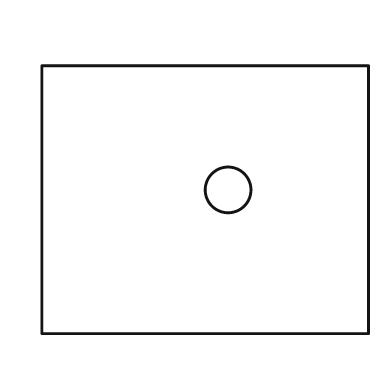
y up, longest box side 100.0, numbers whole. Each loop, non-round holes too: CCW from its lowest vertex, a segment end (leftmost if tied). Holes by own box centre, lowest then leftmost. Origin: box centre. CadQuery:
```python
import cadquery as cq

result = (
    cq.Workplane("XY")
    .moveTo(-50.0, -41.0)
    .lineTo(50.0, -41.0)
    .lineTo(50.0, 41.0)
    .lineTo(-50.0, 41.0)
    .close()
    .moveTo(7.0, 3.0)
    .circle(7.0)
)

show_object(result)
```